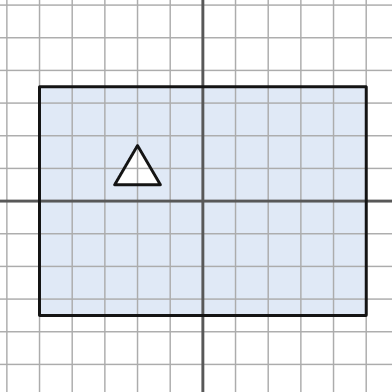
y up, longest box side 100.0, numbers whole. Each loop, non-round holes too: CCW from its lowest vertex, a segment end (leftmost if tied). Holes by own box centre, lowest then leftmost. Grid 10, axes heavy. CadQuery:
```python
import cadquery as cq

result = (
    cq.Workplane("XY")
    .moveTo(-50.0, -35.0)
    .lineTo(50.0, -35.0)
    .lineTo(50.0, 35.0)
    .lineTo(-50.0, 35.0)
    .close()
    .moveTo(-27.0, 5.0)
    .lineTo(-13.0, 5.0)
    .lineTo(-20.0, 17.0)
    .close()
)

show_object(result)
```